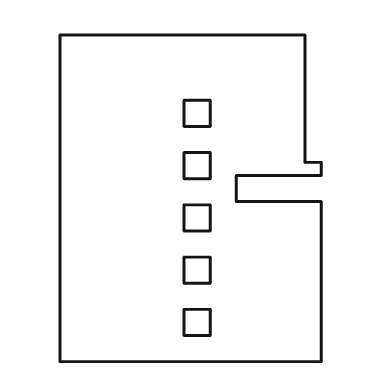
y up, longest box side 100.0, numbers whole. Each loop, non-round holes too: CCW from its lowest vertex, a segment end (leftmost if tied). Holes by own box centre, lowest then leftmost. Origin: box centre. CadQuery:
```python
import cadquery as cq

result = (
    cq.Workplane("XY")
    .moveTo(-40.0, -50.0)
    .lineTo(40.0, -50.0)
    .lineTo(40.0, -1.0)
    .lineTo(14.0, -1.0)
    .lineTo(14.0, 7.0)
    .lineTo(40.0, 7.0)
    .lineTo(40.0, 11.0)
    .lineTo(35.0, 11.0)
    .lineTo(35.0, 50.0)
    .lineTo(-40.0, 50.0)
    .close()
    .moveTo(-2.0, -42.0)
    .lineTo(6.0, -42.0)
    .lineTo(6.0, -34.0)
    .lineTo(-2.0, -34.0)
    .close()
    .moveTo(-2.0, -26.0)
    .lineTo(6.0, -26.0)
    .lineTo(6.0, -18.0)
    .lineTo(-2.0, -18.0)
    .close()
    .moveTo(-2.0, -10.0)
    .lineTo(6.0, -10.0)
    .lineTo(6.0, -2.0)
    .lineTo(-2.0, -2.0)
    .close()
    .moveTo(-2.0, 6.0)
    .lineTo(6.0, 6.0)
    .lineTo(6.0, 14.0)
    .lineTo(-2.0, 14.0)
    .close()
    .moveTo(-2.0, 22.0)
    .lineTo(6.0, 22.0)
    .lineTo(6.0, 30.0)
    .lineTo(-2.0, 30.0)
    .close()
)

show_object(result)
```